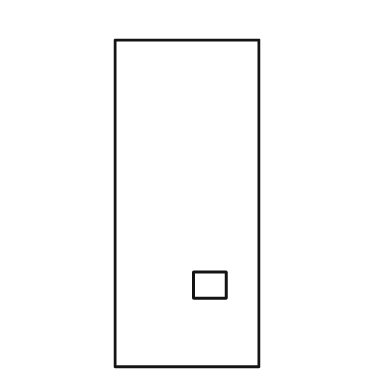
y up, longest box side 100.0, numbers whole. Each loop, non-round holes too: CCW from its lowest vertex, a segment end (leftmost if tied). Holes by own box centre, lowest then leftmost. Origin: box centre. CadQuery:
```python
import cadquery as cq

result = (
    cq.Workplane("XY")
    .moveTo(-22.0, -50.0)
    .lineTo(22.0, -50.0)
    .lineTo(22.0, 50.0)
    .lineTo(-22.0, 50.0)
    .close()
    .moveTo(2.0, -29.0)
    .lineTo(12.0, -29.0)
    .lineTo(12.0, -21.0)
    .lineTo(2.0, -21.0)
    .close()
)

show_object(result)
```